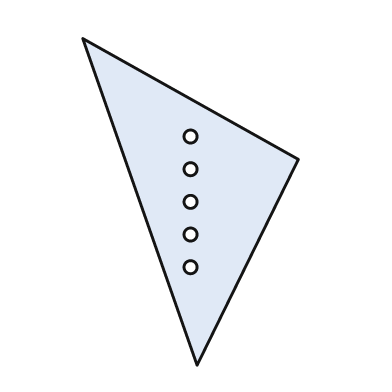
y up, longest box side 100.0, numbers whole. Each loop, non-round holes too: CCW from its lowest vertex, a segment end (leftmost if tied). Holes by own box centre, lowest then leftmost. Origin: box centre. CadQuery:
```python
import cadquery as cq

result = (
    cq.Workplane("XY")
    .moveTo(2.0, -50.0)
    .lineTo(33.0, 13.0)
    .lineTo(-33.0, 50.0)
    .close()
    .moveTo(0.0, -20.0)
    .circle(2.0)
    .moveTo(0.0, -10.0)
    .circle(2.0)
    .moveTo(0.0, 0.0)
    .circle(2.0)
    .moveTo(0.0, 10.0)
    .circle(2.0)
    .moveTo(0.0, 20.0)
    .circle(2.0)
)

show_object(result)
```